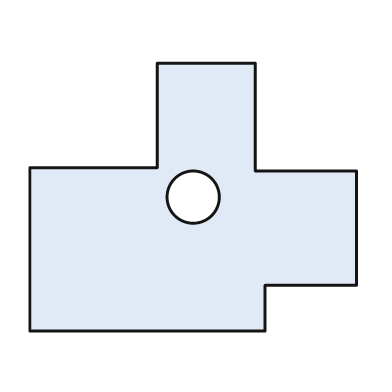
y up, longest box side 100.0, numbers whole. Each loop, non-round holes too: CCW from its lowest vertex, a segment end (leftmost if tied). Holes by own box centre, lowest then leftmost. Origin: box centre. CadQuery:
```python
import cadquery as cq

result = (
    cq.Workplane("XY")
    .moveTo(-50.0, -41.0)
    .lineTo(22.0, -41.0)
    .lineTo(22.0, -27.0)
    .lineTo(50.0, -27.0)
    .lineTo(50.0, 8.0)
    .lineTo(19.0, 8.0)
    .lineTo(19.0, 41.0)
    .lineTo(-11.0, 41.0)
    .lineTo(-11.0, 9.0)
    .lineTo(-50.0, 9.0)
    .close()
    .moveTo(0.0, 0.0)
    .circle(8.0)
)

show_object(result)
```